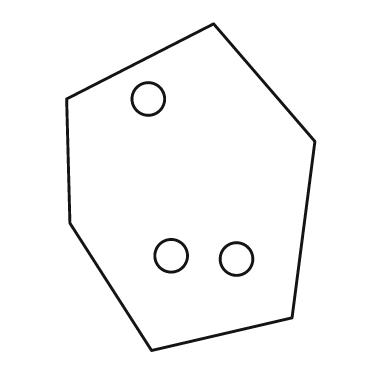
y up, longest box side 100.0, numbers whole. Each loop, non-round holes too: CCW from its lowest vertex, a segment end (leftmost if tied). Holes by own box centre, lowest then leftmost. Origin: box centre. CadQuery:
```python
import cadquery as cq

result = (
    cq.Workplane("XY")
    .moveTo(-12.0, -50.0)
    .lineTo(31.0, -40.0)
    .lineTo(38.0, 14.0)
    .lineTo(7.0, 50.0)
    .lineTo(-38.0, 27.0)
    .lineTo(-37.0, -11.0)
    .close()
    .moveTo(14.0, -22.0)
    .circle(5.0)
    .moveTo(-6.0, -21.0)
    .circle(5.0)
    .moveTo(-13.0, 27.0)
    .circle(5.0)
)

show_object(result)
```